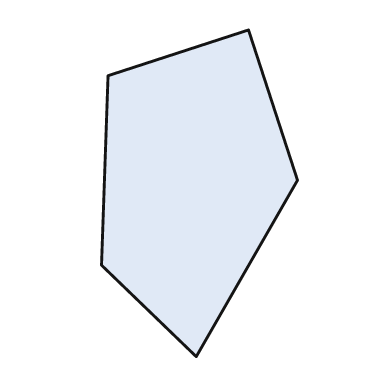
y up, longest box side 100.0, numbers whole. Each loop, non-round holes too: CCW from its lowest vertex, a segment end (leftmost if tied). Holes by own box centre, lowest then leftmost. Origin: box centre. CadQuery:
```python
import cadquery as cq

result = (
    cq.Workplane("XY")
    .moveTo(-1.0, -50.0)
    .lineTo(30.0, 4.0)
    .lineTo(15.0, 50.0)
    .lineTo(-28.0, 36.0)
    .lineTo(-30.0, -22.0)
    .close()
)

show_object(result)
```